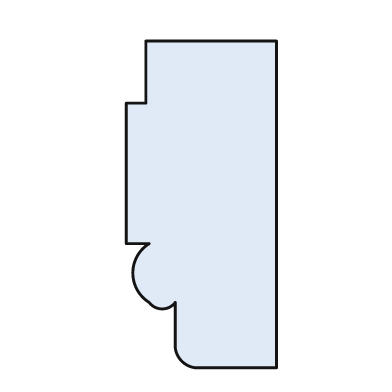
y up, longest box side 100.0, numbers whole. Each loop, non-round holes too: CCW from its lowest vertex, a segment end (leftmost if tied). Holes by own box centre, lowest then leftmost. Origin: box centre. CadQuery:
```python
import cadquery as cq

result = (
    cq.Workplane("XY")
    .moveTo(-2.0, -50.0)
    .lineTo(23.0, -50.0)
    .lineTo(23.0, 50.0)
    .lineTo(-17.0, 50.0)
    .lineTo(-17.0, 31.0)
    .lineTo(-23.0, 31.0)
    .lineTo(-23.0, -12.0)
    .lineTo(-16.0, -12.0)
    .threePointArc((-21.0, -21.0), (-16.0, -30.0))
    .threePointArc((-12.0, -32.0), (-8.0, -30.0))
    .lineTo(-8.0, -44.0)
    .threePointArc((-6.0, -48.0), (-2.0, -50.0))
    .close()
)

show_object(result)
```